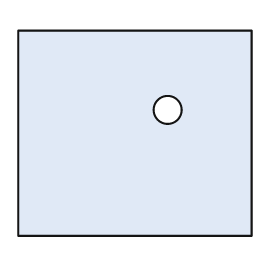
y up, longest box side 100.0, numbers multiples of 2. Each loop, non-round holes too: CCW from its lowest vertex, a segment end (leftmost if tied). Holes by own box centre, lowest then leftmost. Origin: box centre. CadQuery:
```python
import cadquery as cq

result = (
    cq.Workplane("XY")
    .moveTo(-50.0, -44.0)
    .lineTo(50.0, -44.0)
    .lineTo(50.0, 44.0)
    .lineTo(-50.0, 44.0)
    .close()
    .moveTo(14.0, 10.0)
    .circle(6.0)
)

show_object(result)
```